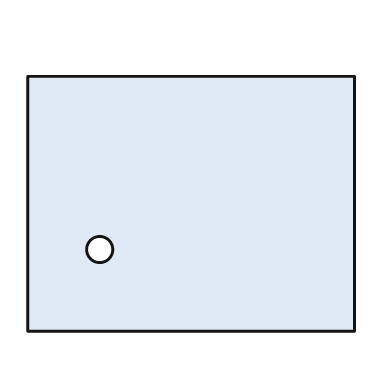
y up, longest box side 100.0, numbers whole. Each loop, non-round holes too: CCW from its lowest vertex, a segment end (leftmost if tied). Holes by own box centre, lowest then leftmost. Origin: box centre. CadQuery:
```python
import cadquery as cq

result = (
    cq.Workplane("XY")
    .moveTo(-50.0, -39.0)
    .lineTo(50.0, -39.0)
    .lineTo(50.0, 39.0)
    .lineTo(-50.0, 39.0)
    .close()
    .moveTo(-28.0, -14.0)
    .circle(4.0)
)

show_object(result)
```